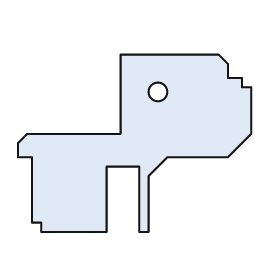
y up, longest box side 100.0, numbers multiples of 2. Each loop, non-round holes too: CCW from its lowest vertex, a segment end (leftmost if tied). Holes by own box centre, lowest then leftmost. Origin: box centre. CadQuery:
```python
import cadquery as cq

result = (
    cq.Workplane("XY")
    .moveTo(-40.0, -38.0)
    .lineTo(-12.0, -38.0)
    .lineTo(-12.0, -10.0)
    .lineTo(2.0, -10.0)
    .lineTo(2.0, -38.0)
    .lineTo(6.0, -38.0)
    .lineTo(6.0, -14.0)
    .lineTo(14.0, -6.0)
    .lineTo(40.0, -6.0)
    .lineTo(50.0, 4.0)
    .lineTo(50.0, 24.0)
    .lineTo(46.0, 24.0)
    .lineTo(46.0, 28.0)
    .lineTo(40.0, 28.0)
    .lineTo(40.0, 34.0)
    .lineTo(36.0, 38.0)
    .lineTo(-6.0, 38.0)
    .lineTo(-6.0, 4.0)
    .lineTo(-46.0, 4.0)
    .lineTo(-50.0, 0.0)
    .lineTo(-50.0, -6.0)
    .lineTo(-44.0, -6.0)
    .lineTo(-44.0, -34.0)
    .lineTo(-40.0, -34.0)
    .close()
    .moveTo(10.0, 22.0)
    .circle(4.0)
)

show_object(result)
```